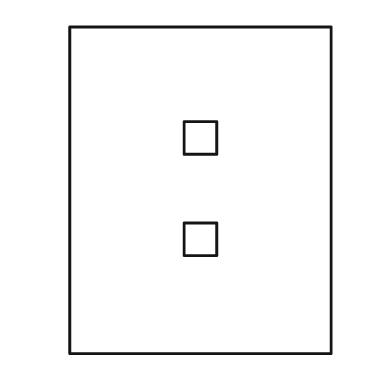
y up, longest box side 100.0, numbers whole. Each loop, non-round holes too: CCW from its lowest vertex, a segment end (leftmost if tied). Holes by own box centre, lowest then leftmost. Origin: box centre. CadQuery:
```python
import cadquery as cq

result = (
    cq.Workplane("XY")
    .moveTo(-40.0, -50.0)
    .lineTo(40.0, -50.0)
    .lineTo(40.0, 50.0)
    .lineTo(-40.0, 50.0)
    .close()
    .moveTo(-5.0, -20.0)
    .lineTo(5.0, -20.0)
    .lineTo(5.0, -10.0)
    .lineTo(-5.0, -10.0)
    .close()
    .moveTo(-5.0, 11.0)
    .lineTo(5.0, 11.0)
    .lineTo(5.0, 21.0)
    .lineTo(-5.0, 21.0)
    .close()
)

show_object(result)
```